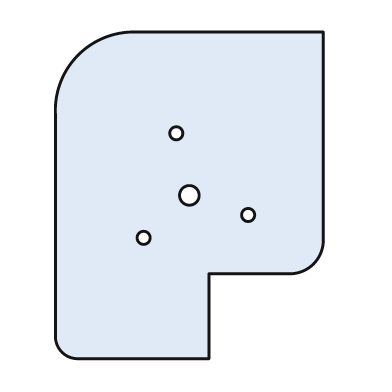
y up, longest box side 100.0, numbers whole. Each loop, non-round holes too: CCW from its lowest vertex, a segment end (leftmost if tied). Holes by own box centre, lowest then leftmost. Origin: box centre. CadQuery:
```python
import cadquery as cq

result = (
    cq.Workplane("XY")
    .moveTo(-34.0, -50.0)
    .lineTo(6.0, -50.0)
    .lineTo(6.0, -24.0)
    .lineTo(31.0, -24.0)
    .threePointArc((38.0, -21.0), (41.0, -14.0))
    .lineTo(41.0, 50.0)
    .lineTo(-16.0, 50.0)
    .threePointArc((-34.0, 43.0), (-41.0, 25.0))
    .lineTo(-41.0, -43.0)
    .threePointArc((-39.0, -48.0), (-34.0, -50.0))
    .close()
    .moveTo(-14.0, -13.0)
    .circle(2.0)
    .moveTo(18.0, -6.0)
    .circle(2.0)
    .moveTo(0.0, 0.0)
    .circle(3.0)
    .moveTo(-4.0, 19.0)
    .circle(2.0)
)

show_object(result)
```